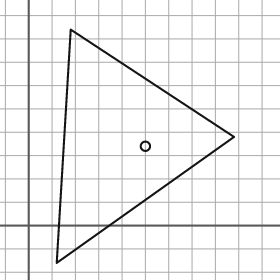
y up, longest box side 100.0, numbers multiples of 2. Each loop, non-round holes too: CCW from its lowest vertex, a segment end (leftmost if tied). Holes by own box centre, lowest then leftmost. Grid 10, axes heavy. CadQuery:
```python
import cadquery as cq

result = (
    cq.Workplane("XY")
    .moveTo(12.0, -16.0)
    .lineTo(88.0, 38.0)
    .lineTo(18.0, 84.0)
    .close()
    .moveTo(50.0, 34.0)
    .circle(2.0)
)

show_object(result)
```